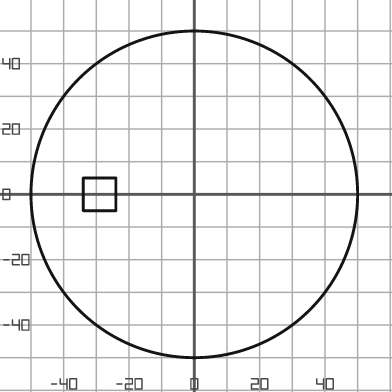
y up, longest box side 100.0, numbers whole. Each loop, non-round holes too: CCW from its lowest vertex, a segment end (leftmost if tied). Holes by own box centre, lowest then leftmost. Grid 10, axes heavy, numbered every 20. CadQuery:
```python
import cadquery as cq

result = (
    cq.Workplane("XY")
    .moveTo(0.0, 0.0)
    .circle(50.0)
    .moveTo(-34.0, -5.0)
    .lineTo(-24.0, -5.0)
    .lineTo(-24.0, 5.0)
    .lineTo(-34.0, 5.0)
    .close()
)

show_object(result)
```